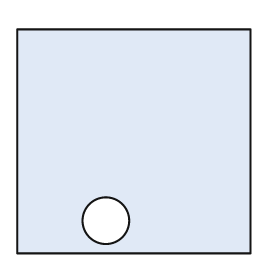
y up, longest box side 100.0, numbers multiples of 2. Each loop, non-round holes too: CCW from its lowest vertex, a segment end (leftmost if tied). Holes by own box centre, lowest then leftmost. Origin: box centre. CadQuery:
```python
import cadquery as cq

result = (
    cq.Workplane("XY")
    .moveTo(-50.0, -48.0)
    .lineTo(50.0, -48.0)
    .lineTo(50.0, 48.0)
    .lineTo(-50.0, 48.0)
    .close()
    .moveTo(-12.0, -34.0)
    .circle(10.0)
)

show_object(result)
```